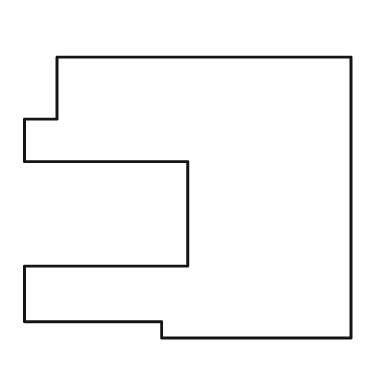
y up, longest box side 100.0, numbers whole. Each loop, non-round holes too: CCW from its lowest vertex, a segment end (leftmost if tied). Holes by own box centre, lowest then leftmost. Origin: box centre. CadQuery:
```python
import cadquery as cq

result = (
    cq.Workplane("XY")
    .moveTo(-8.0, -43.0)
    .lineTo(50.0, -43.0)
    .lineTo(50.0, 43.0)
    .lineTo(-40.0, 43.0)
    .lineTo(-40.0, 24.0)
    .lineTo(-50.0, 24.0)
    .lineTo(-50.0, 11.0)
    .lineTo(0.0, 11.0)
    .lineTo(0.0, -21.0)
    .lineTo(-50.0, -21.0)
    .lineTo(-50.0, -38.0)
    .lineTo(-8.0, -38.0)
    .close()
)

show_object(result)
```